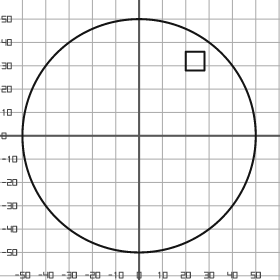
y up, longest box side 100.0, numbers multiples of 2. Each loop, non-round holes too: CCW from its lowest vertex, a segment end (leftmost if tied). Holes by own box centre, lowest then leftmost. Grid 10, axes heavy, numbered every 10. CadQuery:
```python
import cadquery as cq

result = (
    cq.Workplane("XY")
    .moveTo(0.0, 0.0)
    .circle(50.0)
    .moveTo(20.0, 28.0)
    .lineTo(28.0, 28.0)
    .lineTo(28.0, 36.0)
    .lineTo(20.0, 36.0)
    .close()
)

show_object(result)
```